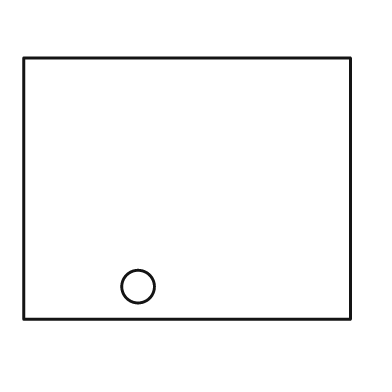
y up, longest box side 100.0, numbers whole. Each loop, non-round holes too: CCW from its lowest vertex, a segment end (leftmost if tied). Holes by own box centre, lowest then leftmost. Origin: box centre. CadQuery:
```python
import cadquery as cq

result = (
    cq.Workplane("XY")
    .moveTo(-50.0, -40.0)
    .lineTo(50.0, -40.0)
    .lineTo(50.0, 40.0)
    .lineTo(-50.0, 40.0)
    .close()
    .moveTo(-15.0, -30.0)
    .circle(5.0)
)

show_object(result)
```